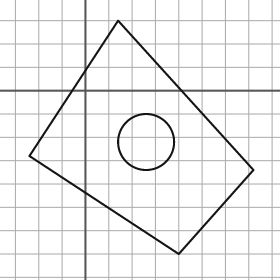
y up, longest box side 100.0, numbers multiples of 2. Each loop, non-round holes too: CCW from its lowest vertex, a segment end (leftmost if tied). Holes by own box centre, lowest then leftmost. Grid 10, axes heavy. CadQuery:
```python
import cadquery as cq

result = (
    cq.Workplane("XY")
    .moveTo(40.0, -70.0)
    .lineTo(72.0, -34.0)
    .lineTo(14.0, 30.0)
    .lineTo(-24.0, -28.0)
    .close()
    .moveTo(26.0, -22.0)
    .circle(12.0)
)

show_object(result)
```